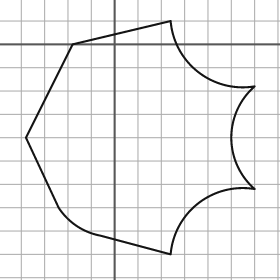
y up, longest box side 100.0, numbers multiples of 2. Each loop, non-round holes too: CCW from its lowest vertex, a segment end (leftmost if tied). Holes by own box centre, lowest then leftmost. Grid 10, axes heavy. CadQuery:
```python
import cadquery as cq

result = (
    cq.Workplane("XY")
    .moveTo(24.0, -90.0)
    .threePointArc((36.0, -68.0), (60.0, -62.0))
    .threePointArc((50.0, -40.0), (60.0, -18.0))
    .threePointArc((36.0, -12.0), (24.0, 10.0))
    .lineTo(-18.0, 0.0)
    .lineTo(-38.0, -40.0)
    .lineTo(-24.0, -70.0)
    .threePointArc((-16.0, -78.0), (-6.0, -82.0))
    .close()
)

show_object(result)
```